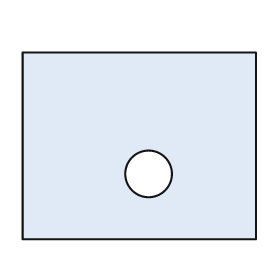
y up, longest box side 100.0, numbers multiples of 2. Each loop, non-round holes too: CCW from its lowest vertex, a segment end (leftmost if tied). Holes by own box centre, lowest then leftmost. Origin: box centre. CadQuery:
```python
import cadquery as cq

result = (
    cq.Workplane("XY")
    .moveTo(-50.0, -40.0)
    .lineTo(50.0, -40.0)
    .lineTo(50.0, 40.0)
    .lineTo(-50.0, 40.0)
    .close()
    .moveTo(4.0, -12.0)
    .circle(10.0)
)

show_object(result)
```